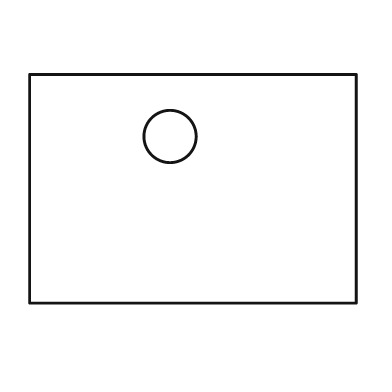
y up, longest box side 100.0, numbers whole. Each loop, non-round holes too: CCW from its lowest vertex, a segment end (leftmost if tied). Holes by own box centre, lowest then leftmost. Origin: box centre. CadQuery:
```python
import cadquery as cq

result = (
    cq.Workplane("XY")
    .moveTo(-50.0, -35.0)
    .lineTo(50.0, -35.0)
    .lineTo(50.0, 35.0)
    .lineTo(-50.0, 35.0)
    .close()
    .moveTo(-7.0, 16.0)
    .circle(8.0)
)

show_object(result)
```